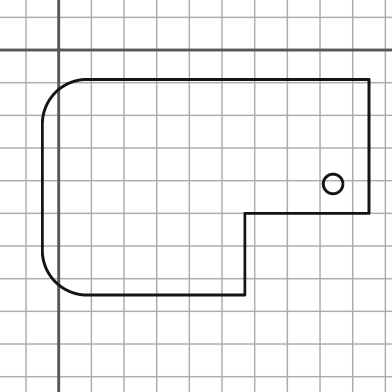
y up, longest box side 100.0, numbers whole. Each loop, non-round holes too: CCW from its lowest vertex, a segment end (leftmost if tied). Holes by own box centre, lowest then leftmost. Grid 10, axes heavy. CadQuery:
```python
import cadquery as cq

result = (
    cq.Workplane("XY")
    .moveTo(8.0, -75.0)
    .lineTo(57.0, -75.0)
    .lineTo(57.0, -50.0)
    .lineTo(95.0, -50.0)
    .lineTo(95.0, -9.0)
    .lineTo(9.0, -9.0)
    .threePointArc((-1.0, -13.0), (-5.0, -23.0))
    .lineTo(-5.0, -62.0)
    .threePointArc((-1.0, -71.0), (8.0, -75.0))
    .close()
    .moveTo(84.0, -41.0)
    .circle(3.0)
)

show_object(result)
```